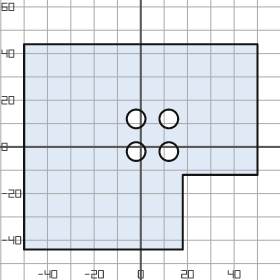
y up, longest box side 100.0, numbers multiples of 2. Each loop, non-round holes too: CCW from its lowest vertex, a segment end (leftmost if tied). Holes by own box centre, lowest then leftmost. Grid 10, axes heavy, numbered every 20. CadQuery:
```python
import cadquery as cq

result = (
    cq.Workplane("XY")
    .moveTo(-50.0, -44.0)
    .lineTo(18.0, -44.0)
    .lineTo(18.0, -12.0)
    .lineTo(50.0, -12.0)
    .lineTo(50.0, 44.0)
    .lineTo(-50.0, 44.0)
    .close()
    .moveTo(-2.0, -2.0)
    .circle(4.0)
    .moveTo(12.0, -2.0)
    .circle(4.0)
    .moveTo(-2.0, 12.0)
    .circle(4.0)
    .moveTo(12.0, 12.0)
    .circle(4.0)
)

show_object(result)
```